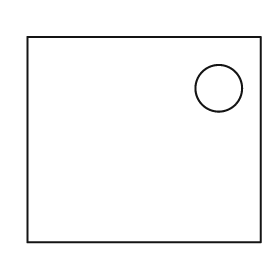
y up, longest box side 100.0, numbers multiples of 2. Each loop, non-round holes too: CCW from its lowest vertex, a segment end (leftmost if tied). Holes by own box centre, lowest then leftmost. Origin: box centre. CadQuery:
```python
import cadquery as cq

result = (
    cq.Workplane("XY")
    .moveTo(-50.0, -44.0)
    .lineTo(50.0, -44.0)
    .lineTo(50.0, 44.0)
    .lineTo(-50.0, 44.0)
    .close()
    .moveTo(32.0, 22.0)
    .circle(10.0)
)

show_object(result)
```